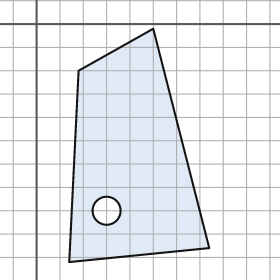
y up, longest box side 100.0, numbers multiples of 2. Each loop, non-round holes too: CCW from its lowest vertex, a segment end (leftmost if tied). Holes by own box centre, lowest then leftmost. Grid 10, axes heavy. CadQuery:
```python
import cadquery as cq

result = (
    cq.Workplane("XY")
    .moveTo(14.0, -102.0)
    .lineTo(74.0, -96.0)
    .lineTo(50.0, -2.0)
    .lineTo(18.0, -20.0)
    .close()
    .moveTo(30.0, -80.0)
    .circle(6.0)
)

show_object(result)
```